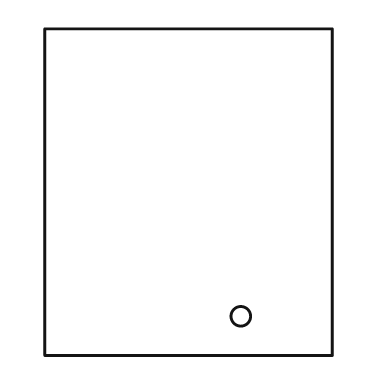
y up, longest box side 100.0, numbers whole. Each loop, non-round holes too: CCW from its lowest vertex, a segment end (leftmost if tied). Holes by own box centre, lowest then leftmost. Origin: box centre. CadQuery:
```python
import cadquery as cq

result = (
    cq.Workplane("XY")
    .moveTo(-44.0, -50.0)
    .lineTo(44.0, -50.0)
    .lineTo(44.0, 50.0)
    .lineTo(-44.0, 50.0)
    .close()
    .moveTo(16.0, -38.0)
    .circle(3.0)
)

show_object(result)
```